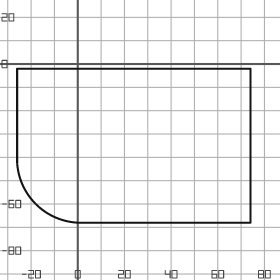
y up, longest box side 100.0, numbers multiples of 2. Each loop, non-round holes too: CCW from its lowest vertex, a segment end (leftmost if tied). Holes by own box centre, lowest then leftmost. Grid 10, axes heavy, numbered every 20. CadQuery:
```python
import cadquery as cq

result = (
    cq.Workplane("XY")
    .moveTo(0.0, -68.0)
    .lineTo(74.0, -68.0)
    .lineTo(74.0, -2.0)
    .lineTo(-26.0, -2.0)
    .lineTo(-26.0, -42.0)
    .threePointArc((-18.0, -60.0), (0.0, -68.0))
    .close()
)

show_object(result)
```